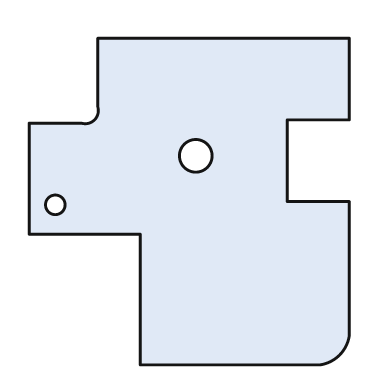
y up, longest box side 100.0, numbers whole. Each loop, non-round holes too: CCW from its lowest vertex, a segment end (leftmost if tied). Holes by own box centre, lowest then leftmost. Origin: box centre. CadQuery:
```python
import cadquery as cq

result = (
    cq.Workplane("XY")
    .moveTo(-15.0, -50.0)
    .lineTo(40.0, -50.0)
    .threePointArc((46.0, -47.0), (49.0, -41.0))
    .lineTo(49.0, 0.0)
    .lineTo(30.0, 0.0)
    .lineTo(30.0, 25.0)
    .lineTo(49.0, 25.0)
    .lineTo(49.0, 50.0)
    .lineTo(-28.0, 50.0)
    .lineTo(-28.0, 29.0)
    .threePointArc((-29.0, 25.0), (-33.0, 24.0))
    .lineTo(-49.0, 24.0)
    .lineTo(-49.0, -10.0)
    .lineTo(-15.0, -10.0)
    .close()
    .moveTo(-41.0, -1.0)
    .circle(3.0)
    .moveTo(2.0, 14.0)
    .circle(5.0)
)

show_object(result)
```